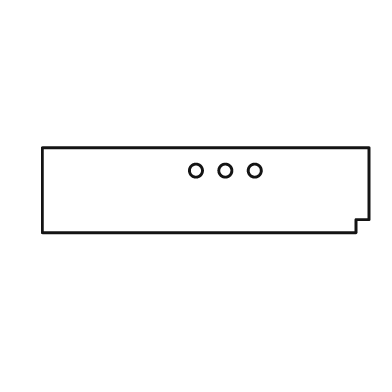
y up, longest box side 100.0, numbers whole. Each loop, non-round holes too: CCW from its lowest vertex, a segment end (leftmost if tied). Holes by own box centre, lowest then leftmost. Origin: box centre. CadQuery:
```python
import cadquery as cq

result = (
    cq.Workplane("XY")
    .moveTo(-50.0, -13.0)
    .lineTo(46.0, -13.0)
    .lineTo(46.0, -9.0)
    .lineTo(50.0, -9.0)
    .lineTo(50.0, 13.0)
    .lineTo(-50.0, 13.0)
    .close()
    .moveTo(-3.0, 6.0)
    .circle(2.0)
    .moveTo(6.0, 6.0)
    .circle(2.0)
    .moveTo(15.0, 6.0)
    .circle(2.0)
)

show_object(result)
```